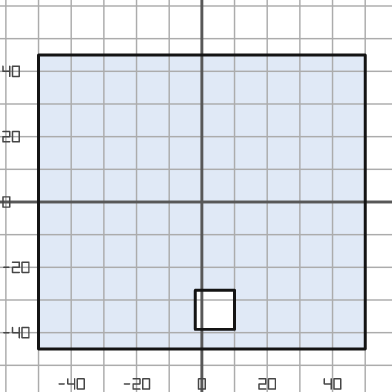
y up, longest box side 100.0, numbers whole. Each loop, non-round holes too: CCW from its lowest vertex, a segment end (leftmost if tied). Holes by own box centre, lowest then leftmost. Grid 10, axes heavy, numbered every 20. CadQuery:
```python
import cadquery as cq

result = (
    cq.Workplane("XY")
    .moveTo(-50.0, -45.0)
    .lineTo(50.0, -45.0)
    .lineTo(50.0, 45.0)
    .lineTo(-50.0, 45.0)
    .close()
    .moveTo(-2.0, -39.0)
    .lineTo(10.0, -39.0)
    .lineTo(10.0, -27.0)
    .lineTo(-2.0, -27.0)
    .close()
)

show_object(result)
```